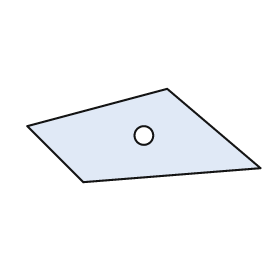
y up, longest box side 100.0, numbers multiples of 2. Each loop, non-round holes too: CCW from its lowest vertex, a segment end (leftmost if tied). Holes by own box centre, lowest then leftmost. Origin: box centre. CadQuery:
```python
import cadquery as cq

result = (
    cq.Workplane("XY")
    .moveTo(-26.0, -20.0)
    .lineTo(50.0, -14.0)
    .lineTo(10.0, 20.0)
    .lineTo(-50.0, 4.0)
    .close()
    .moveTo(0.0, 0.0)
    .circle(4.0)
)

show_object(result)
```